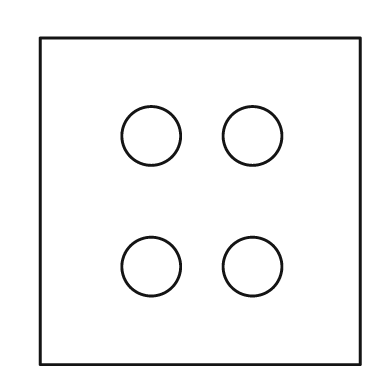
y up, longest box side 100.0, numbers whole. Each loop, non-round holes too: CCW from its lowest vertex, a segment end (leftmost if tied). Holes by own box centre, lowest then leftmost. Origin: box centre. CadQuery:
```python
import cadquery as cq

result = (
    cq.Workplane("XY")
    .moveTo(-49.0, -50.0)
    .lineTo(49.0, -50.0)
    .lineTo(49.0, 50.0)
    .lineTo(-49.0, 50.0)
    .close()
    .moveTo(-15.0, -20.0)
    .circle(9.0)
    .moveTo(16.0, -20.0)
    .circle(9.0)
    .moveTo(-15.0, 20.0)
    .circle(9.0)
    .moveTo(16.0, 20.0)
    .circle(9.0)
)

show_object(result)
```